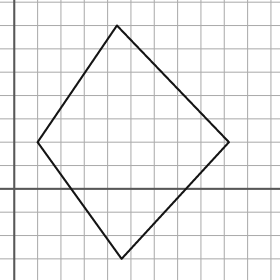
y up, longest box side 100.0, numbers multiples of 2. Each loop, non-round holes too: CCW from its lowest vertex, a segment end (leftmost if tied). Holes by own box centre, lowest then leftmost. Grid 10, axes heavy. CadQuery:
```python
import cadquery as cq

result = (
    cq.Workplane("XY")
    .moveTo(46.0, -30.0)
    .lineTo(92.0, 20.0)
    .lineTo(44.0, 70.0)
    .lineTo(10.0, 20.0)
    .close()
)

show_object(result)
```